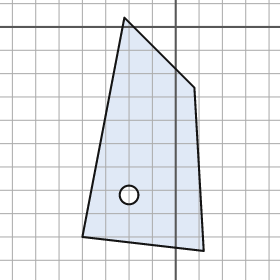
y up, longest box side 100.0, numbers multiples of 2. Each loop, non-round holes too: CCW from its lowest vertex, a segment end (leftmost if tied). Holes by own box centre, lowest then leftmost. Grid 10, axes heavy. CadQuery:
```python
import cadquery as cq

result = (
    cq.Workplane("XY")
    .moveTo(12.0, -96.0)
    .lineTo(8.0, -26.0)
    .lineTo(-22.0, 4.0)
    .lineTo(-40.0, -90.0)
    .close()
    .moveTo(-20.0, -72.0)
    .circle(4.0)
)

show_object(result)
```